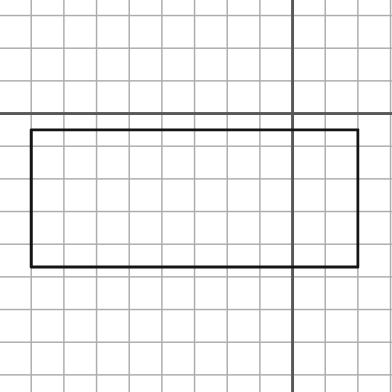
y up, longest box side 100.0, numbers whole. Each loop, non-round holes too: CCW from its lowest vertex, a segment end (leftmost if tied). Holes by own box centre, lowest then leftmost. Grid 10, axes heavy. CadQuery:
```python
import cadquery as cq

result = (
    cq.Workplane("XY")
    .moveTo(-80.0, -47.0)
    .lineTo(20.0, -47.0)
    .lineTo(20.0, -5.0)
    .lineTo(-80.0, -5.0)
    .close()
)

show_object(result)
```